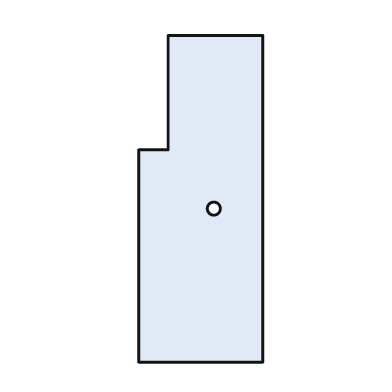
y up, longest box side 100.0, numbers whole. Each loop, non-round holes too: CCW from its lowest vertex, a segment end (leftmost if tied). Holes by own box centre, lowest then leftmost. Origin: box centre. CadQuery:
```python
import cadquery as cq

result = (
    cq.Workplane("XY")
    .moveTo(-19.0, -50.0)
    .lineTo(19.0, -50.0)
    .lineTo(19.0, 50.0)
    .lineTo(-10.0, 50.0)
    .lineTo(-10.0, 15.0)
    .lineTo(-19.0, 15.0)
    .close()
    .moveTo(4.0, -3.0)
    .circle(2.0)
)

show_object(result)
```